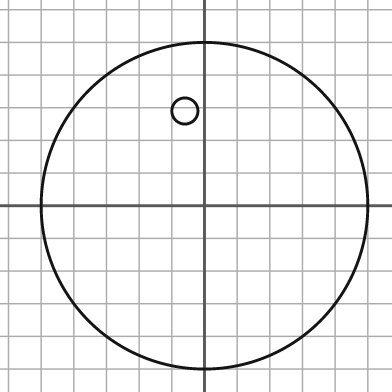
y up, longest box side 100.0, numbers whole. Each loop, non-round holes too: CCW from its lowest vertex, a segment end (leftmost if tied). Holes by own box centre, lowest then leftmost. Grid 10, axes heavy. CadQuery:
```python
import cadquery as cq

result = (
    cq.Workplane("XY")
    .moveTo(0.0, 0.0)
    .circle(50.0)
    .moveTo(-6.0, 29.0)
    .circle(4.0)
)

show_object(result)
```